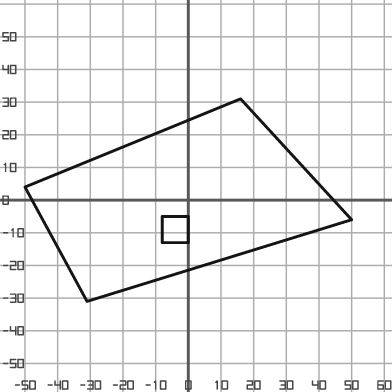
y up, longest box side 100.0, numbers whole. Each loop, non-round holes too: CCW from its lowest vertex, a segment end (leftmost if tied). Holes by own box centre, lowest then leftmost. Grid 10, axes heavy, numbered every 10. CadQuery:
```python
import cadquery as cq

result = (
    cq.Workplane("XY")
    .moveTo(-31.0, -31.0)
    .lineTo(50.0, -6.0)
    .lineTo(16.0, 31.0)
    .lineTo(-50.0, 4.0)
    .close()
    .moveTo(-8.0, -13.0)
    .lineTo(0.0, -13.0)
    .lineTo(0.0, -5.0)
    .lineTo(-8.0, -5.0)
    .close()
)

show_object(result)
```